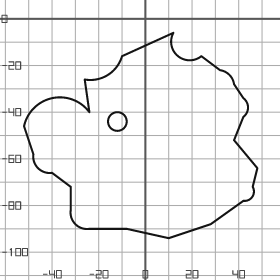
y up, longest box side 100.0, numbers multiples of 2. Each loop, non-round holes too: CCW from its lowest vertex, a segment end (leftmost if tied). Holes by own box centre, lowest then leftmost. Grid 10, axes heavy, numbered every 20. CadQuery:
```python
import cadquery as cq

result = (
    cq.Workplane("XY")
    .moveTo(10.0, -94.0)
    .lineTo(28.0, -88.0)
    .lineTo(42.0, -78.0)
    .threePointArc((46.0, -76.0), (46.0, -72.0))
    .lineTo(48.0, -64.0)
    .lineTo(38.0, -52.0)
    .lineTo(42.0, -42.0)
    .threePointArc((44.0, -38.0), (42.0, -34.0))
    .lineTo(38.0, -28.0)
    .threePointArc((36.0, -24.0), (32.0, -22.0))
    .lineTo(24.0, -16.0)
    .threePointArc((14.0, -16.0), (12.0, -6.0))
    .lineTo(-10.0, -16.0)
    .threePointArc((-16.0, -24.0), (-26.0, -26.0))
    .lineTo(-24.0, -40.0)
    .threePointArc((-40.0, -34.0), (-52.0, -46.0))
    .lineTo(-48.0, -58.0)
    .threePointArc((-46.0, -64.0), (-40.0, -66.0))
    .lineTo(-32.0, -72.0)
    .lineTo(-32.0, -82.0)
    .threePointArc((-30.0, -88.0), (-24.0, -90.0))
    .lineTo(-8.0, -90.0)
    .close()
    .moveTo(-12.0, -44.0)
    .circle(4.0)
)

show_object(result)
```